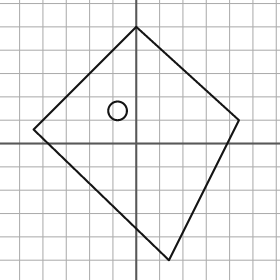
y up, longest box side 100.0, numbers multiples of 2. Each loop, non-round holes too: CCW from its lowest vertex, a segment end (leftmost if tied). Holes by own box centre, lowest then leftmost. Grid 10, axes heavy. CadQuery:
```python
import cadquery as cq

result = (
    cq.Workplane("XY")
    .moveTo(14.0, -50.0)
    .lineTo(44.0, 10.0)
    .lineTo(0.0, 50.0)
    .lineTo(-44.0, 6.0)
    .close()
    .moveTo(-8.0, 14.0)
    .circle(4.0)
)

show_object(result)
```